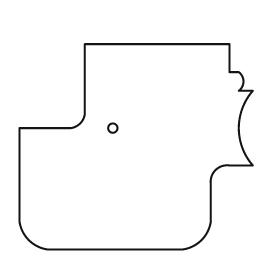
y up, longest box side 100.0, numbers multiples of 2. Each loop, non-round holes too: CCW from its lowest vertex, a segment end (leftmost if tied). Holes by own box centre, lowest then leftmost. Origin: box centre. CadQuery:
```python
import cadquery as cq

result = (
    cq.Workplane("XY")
    .moveTo(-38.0, -44.0)
    .lineTo(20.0, -44.0)
    .threePointArc((28.0, -40.0), (32.0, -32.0))
    .lineTo(32.0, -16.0)
    .threePointArc((34.0, -10.0), (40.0, -8.0))
    .lineTo(50.0, -8.0)
    .threePointArc((44.0, 8.0), (50.0, 24.0))
    .lineTo(44.0, 24.0)
    .threePointArc((46.0, 28.0), (44.0, 32.0))
    .lineTo(40.0, 32.0)
    .lineTo(40.0, 44.0)
    .lineTo(-22.0, 44.0)
    .lineTo(-22.0, 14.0)
    .threePointArc((-24.0, 10.0), (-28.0, 8.0))
    .lineTo(-50.0, 8.0)
    .lineTo(-50.0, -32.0)
    .threePointArc((-46.0, -40.0), (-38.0, -44.0))
    .close()
    .moveTo(-10.0, 8.0)
    .circle(2.0)
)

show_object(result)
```